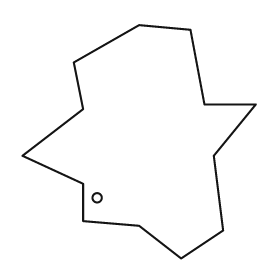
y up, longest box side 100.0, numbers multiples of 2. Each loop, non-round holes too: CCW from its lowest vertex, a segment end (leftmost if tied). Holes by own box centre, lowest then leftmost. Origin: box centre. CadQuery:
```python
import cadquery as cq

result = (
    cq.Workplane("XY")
    .moveTo(18.0, -50.0)
    .lineTo(36.0, -38.0)
    .lineTo(32.0, -6.0)
    .lineTo(50.0, 16.0)
    .lineTo(28.0, 16.0)
    .lineTo(22.0, 48.0)
    .lineTo(0.0, 50.0)
    .lineTo(-28.0, 34.0)
    .lineTo(-24.0, 14.0)
    .lineTo(-50.0, -6.0)
    .lineTo(-24.0, -18.0)
    .lineTo(-24.0, -34.0)
    .lineTo(0.0, -36.0)
    .close()
    .moveTo(-18.0, -24.0)
    .circle(2.0)
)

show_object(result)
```